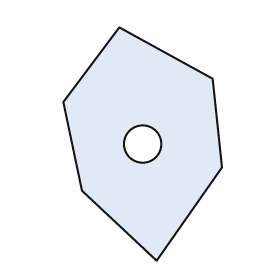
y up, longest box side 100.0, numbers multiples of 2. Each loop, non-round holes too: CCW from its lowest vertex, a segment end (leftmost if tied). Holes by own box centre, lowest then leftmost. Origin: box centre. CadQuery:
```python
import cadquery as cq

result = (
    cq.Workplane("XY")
    .moveTo(6.0, -50.0)
    .lineTo(34.0, -10.0)
    .lineTo(30.0, 28.0)
    .lineTo(-10.0, 50.0)
    .lineTo(-34.0, 18.0)
    .lineTo(-26.0, -20.0)
    .close()
    .moveTo(0.0, 0.0)
    .circle(8.0)
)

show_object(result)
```